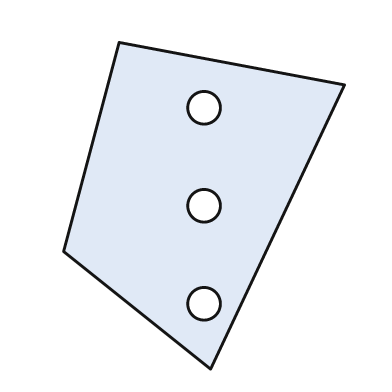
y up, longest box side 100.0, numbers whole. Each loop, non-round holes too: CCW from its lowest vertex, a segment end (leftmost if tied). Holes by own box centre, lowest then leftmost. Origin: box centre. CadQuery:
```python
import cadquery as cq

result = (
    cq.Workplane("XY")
    .moveTo(2.0, -50.0)
    .lineTo(43.0, 37.0)
    .lineTo(-26.0, 50.0)
    .lineTo(-43.0, -14.0)
    .close()
    .moveTo(0.0, -30.0)
    .circle(5.0)
    .moveTo(0.0, 0.0)
    .circle(5.0)
    .moveTo(0.0, 30.0)
    .circle(5.0)
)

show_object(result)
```